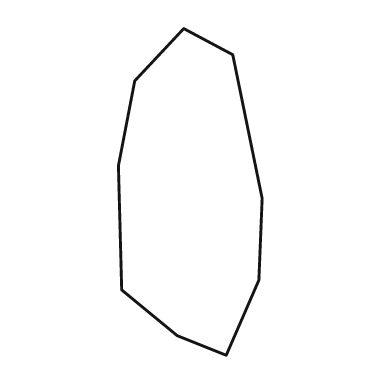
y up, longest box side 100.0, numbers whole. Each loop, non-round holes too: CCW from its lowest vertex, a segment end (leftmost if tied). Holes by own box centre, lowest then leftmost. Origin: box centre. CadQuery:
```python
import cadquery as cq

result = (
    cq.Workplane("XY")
    .moveTo(11.0, -50.0)
    .lineTo(21.0, -27.0)
    .lineTo(22.0, -2.0)
    .lineTo(13.0, 42.0)
    .lineTo(-2.0, 50.0)
    .lineTo(-17.0, 34.0)
    .lineTo(-22.0, 8.0)
    .lineTo(-21.0, -30.0)
    .lineTo(-4.0, -44.0)
    .close()
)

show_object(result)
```